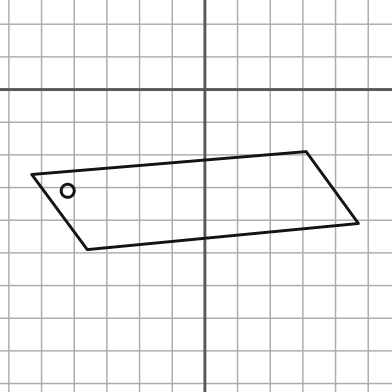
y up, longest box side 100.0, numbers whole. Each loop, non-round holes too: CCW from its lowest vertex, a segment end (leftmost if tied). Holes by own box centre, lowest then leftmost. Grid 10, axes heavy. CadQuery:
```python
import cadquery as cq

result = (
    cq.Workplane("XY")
    .moveTo(-36.0, -49.0)
    .lineTo(47.0, -41.0)
    .lineTo(31.0, -19.0)
    .lineTo(-53.0, -26.0)
    .close()
    .moveTo(-42.0, -31.0)
    .circle(2.0)
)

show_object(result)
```